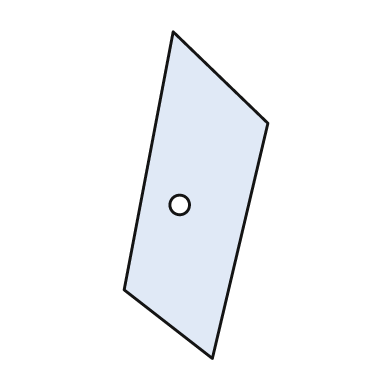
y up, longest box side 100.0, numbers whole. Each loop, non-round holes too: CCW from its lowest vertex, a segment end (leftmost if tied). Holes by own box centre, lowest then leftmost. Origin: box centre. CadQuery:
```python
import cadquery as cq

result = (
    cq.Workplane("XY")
    .moveTo(5.0, -50.0)
    .lineTo(22.0, 22.0)
    .lineTo(-7.0, 50.0)
    .lineTo(-22.0, -29.0)
    .close()
    .moveTo(-5.0, -3.0)
    .circle(3.0)
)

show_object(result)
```